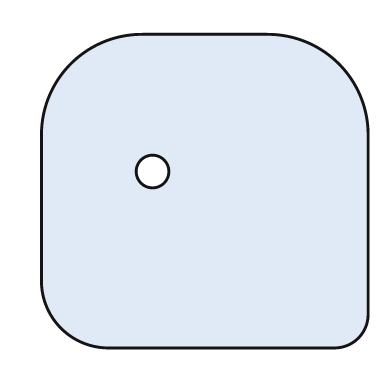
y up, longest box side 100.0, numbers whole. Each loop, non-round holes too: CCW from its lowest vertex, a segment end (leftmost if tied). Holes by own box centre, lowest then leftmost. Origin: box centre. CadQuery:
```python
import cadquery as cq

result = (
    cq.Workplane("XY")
    .moveTo(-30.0, -48.0)
    .lineTo(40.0, -48.0)
    .threePointArc((47.0, -45.0), (50.0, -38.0))
    .lineTo(50.0, 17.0)
    .threePointArc((41.0, 39.0), (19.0, 48.0))
    .lineTo(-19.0, 48.0)
    .threePointArc((-41.0, 39.0), (-50.0, 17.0))
    .lineTo(-50.0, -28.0)
    .threePointArc((-44.0, -42.0), (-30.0, -48.0))
    .close()
    .moveTo(-16.0, 6.0)
    .circle(5.0)
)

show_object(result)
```